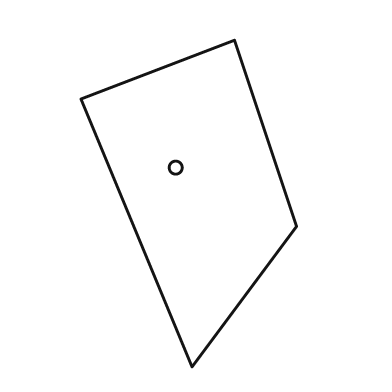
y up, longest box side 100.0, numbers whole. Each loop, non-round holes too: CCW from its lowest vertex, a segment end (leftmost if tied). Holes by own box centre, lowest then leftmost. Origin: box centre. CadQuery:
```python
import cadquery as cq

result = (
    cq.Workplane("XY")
    .moveTo(1.0, -50.0)
    .lineTo(33.0, -7.0)
    .lineTo(14.0, 50.0)
    .lineTo(-33.0, 32.0)
    .close()
    .moveTo(-4.0, 11.0)
    .circle(2.0)
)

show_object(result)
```